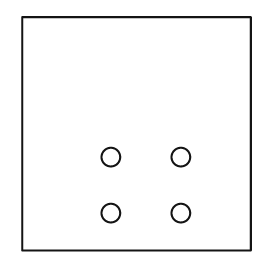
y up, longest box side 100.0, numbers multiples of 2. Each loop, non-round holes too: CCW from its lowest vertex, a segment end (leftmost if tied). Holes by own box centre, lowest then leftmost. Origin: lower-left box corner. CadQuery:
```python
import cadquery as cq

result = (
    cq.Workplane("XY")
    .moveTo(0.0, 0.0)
    .lineTo(98.0, 0.0)
    .lineTo(98.0, 100.0)
    .lineTo(0.0, 100.0)
    .close()
    .moveTo(38.0, 16.0)
    .circle(4.0)
    .moveTo(68.0, 16.0)
    .circle(4.0)
    .moveTo(38.0, 40.0)
    .circle(4.0)
    .moveTo(68.0, 40.0)
    .circle(4.0)
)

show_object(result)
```